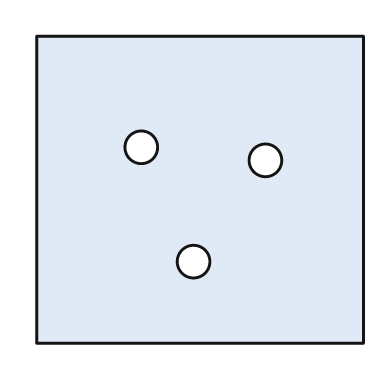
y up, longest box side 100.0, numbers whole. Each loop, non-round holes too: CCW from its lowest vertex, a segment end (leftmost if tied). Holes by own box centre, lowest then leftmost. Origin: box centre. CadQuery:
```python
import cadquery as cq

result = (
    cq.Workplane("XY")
    .moveTo(-50.0, -47.0)
    .lineTo(50.0, -47.0)
    .lineTo(50.0, 47.0)
    .lineTo(-50.0, 47.0)
    .close()
    .moveTo(-2.0, -22.0)
    .circle(5.0)
    .moveTo(20.0, 9.0)
    .circle(5.0)
    .moveTo(-18.0, 13.0)
    .circle(5.0)
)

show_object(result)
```